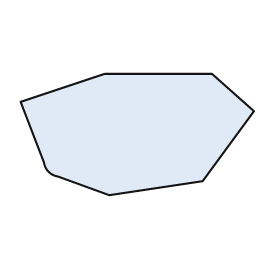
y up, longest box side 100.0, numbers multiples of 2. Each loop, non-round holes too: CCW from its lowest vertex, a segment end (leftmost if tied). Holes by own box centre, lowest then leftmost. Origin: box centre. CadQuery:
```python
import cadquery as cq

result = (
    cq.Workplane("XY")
    .moveTo(-12.0, -26.0)
    .lineTo(28.0, -20.0)
    .lineTo(50.0, 10.0)
    .lineTo(32.0, 26.0)
    .lineTo(-14.0, 26.0)
    .lineTo(-50.0, 14.0)
    .lineTo(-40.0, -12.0)
    .threePointArc((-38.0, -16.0), (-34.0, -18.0))
    .close()
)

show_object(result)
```